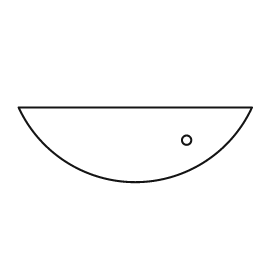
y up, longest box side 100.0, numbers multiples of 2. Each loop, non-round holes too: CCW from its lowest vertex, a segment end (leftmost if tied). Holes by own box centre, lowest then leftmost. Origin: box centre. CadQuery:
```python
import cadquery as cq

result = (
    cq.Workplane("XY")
    .moveTo(-50.0, 16.0)
    .threePointArc((0.0, -16.0), (50.0, 16.0))
    .close()
    .moveTo(22.0, 2.0)
    .circle(2.0)
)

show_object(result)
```